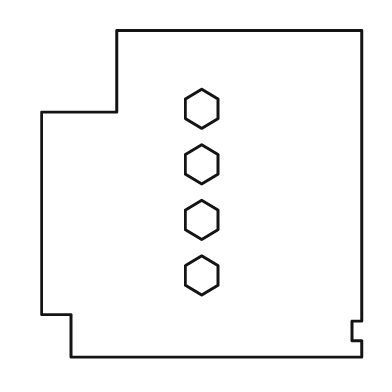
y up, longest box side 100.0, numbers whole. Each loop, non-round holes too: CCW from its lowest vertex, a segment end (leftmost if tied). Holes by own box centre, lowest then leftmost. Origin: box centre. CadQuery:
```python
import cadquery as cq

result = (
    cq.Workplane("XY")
    .moveTo(-40.0, -50.0)
    .lineTo(49.0, -50.0)
    .lineTo(49.0, -45.0)
    .lineTo(46.0, -45.0)
    .lineTo(46.0, -39.0)
    .lineTo(49.0, -39.0)
    .lineTo(49.0, 50.0)
    .lineTo(-26.0, 50.0)
    .lineTo(-26.0, 25.0)
    .lineTo(-49.0, 25.0)
    .lineTo(-49.0, -37.0)
    .lineTo(-40.0, -37.0)
    .close()
    .moveTo(0.0, -31.0)
    .lineTo(5.0, -28.0)
    .lineTo(5.0, -22.0)
    .lineTo(0.0, -19.0)
    .lineTo(-5.0, -22.0)
    .lineTo(-5.0, -28.0)
    .close()
    .moveTo(0.0, -14.0)
    .lineTo(5.0, -11.0)
    .lineTo(5.0, -5.0)
    .lineTo(0.0, -2.0)
    .lineTo(-5.0, -5.0)
    .lineTo(-5.0, -11.0)
    .close()
    .moveTo(0.0, 3.0)
    .lineTo(5.0, 6.0)
    .lineTo(5.0, 12.0)
    .lineTo(0.0, 15.0)
    .lineTo(-5.0, 12.0)
    .lineTo(-5.0, 6.0)
    .close()
    .moveTo(0.0, 20.0)
    .lineTo(5.0, 23.0)
    .lineTo(5.0, 29.0)
    .lineTo(0.0, 32.0)
    .lineTo(-5.0, 29.0)
    .lineTo(-5.0, 23.0)
    .close()
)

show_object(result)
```